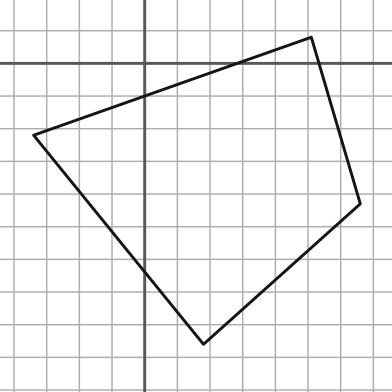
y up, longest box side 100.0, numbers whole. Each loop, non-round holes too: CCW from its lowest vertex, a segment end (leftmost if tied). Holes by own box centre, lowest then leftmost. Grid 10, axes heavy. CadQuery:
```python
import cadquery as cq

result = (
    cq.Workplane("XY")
    .moveTo(18.0, -86.0)
    .lineTo(66.0, -43.0)
    .lineTo(51.0, 8.0)
    .lineTo(-34.0, -22.0)
    .close()
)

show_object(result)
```